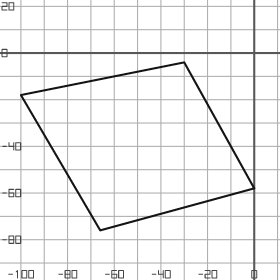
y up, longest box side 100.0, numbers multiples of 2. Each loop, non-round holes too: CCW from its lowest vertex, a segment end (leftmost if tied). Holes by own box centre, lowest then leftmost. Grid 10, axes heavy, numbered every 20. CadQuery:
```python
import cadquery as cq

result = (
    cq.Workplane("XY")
    .moveTo(-66.0, -76.0)
    .lineTo(0.0, -58.0)
    .lineTo(-30.0, -4.0)
    .lineTo(-100.0, -18.0)
    .close()
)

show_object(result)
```